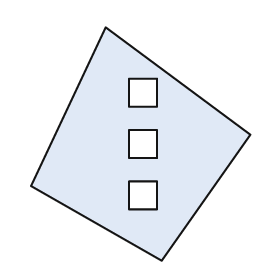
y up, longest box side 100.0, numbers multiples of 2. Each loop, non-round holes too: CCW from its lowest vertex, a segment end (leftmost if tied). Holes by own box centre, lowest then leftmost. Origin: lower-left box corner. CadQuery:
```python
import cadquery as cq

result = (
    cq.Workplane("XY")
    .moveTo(56.0, 0.0)
    .lineTo(94.0, 54.0)
    .lineTo(32.0, 100.0)
    .lineTo(0.0, 32.0)
    .close()
    .moveTo(42.0, 22.0)
    .lineTo(54.0, 22.0)
    .lineTo(54.0, 34.0)
    .lineTo(42.0, 34.0)
    .close()
    .moveTo(42.0, 44.0)
    .lineTo(54.0, 44.0)
    .lineTo(54.0, 56.0)
    .lineTo(42.0, 56.0)
    .close()
    .moveTo(42.0, 66.0)
    .lineTo(54.0, 66.0)
    .lineTo(54.0, 78.0)
    .lineTo(42.0, 78.0)
    .close()
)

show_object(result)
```